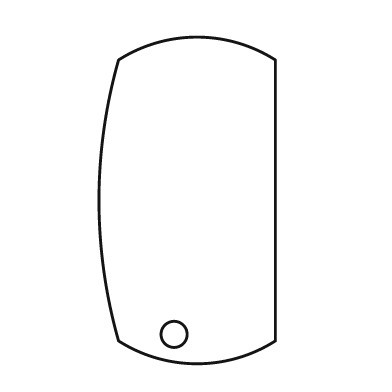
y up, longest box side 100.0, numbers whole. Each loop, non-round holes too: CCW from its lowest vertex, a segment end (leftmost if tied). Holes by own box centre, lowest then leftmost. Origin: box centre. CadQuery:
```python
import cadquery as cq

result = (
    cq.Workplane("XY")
    .moveTo(-21.0, -43.0)
    .threePointArc((3.0, -50.0), (27.0, -43.0))
    .lineTo(27.0, 43.0)
    .threePointArc((3.0, 50.0), (-21.0, 43.0))
    .threePointArc((-27.0, 0.0), (-21.0, -43.0))
    .close()
    .moveTo(-4.0, -41.0)
    .circle(4.0)
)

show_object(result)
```